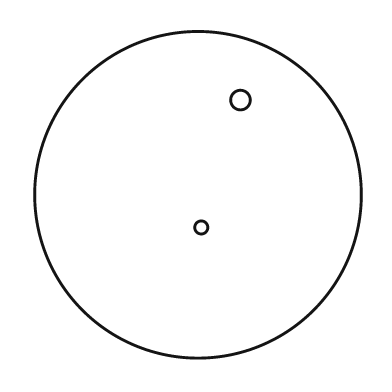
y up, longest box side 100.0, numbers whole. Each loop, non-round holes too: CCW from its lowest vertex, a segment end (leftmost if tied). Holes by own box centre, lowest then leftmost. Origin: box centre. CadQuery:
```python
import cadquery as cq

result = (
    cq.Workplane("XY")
    .moveTo(0.0, 0.0)
    .circle(50.0)
    .moveTo(1.0, -10.0)
    .circle(2.0)
    .moveTo(13.0, 29.0)
    .circle(3.0)
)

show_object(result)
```